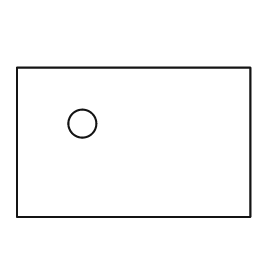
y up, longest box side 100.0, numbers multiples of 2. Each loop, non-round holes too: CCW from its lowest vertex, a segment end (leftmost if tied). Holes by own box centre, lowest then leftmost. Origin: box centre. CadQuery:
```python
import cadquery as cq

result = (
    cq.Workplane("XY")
    .moveTo(-50.0, -32.0)
    .lineTo(50.0, -32.0)
    .lineTo(50.0, 32.0)
    .lineTo(-50.0, 32.0)
    .close()
    .moveTo(-22.0, 8.0)
    .circle(6.0)
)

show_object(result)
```